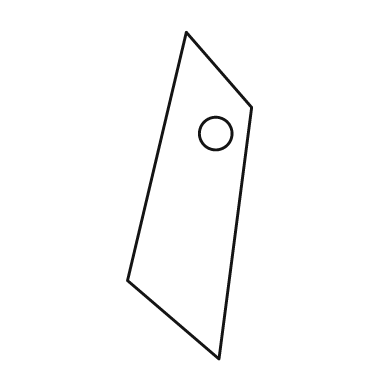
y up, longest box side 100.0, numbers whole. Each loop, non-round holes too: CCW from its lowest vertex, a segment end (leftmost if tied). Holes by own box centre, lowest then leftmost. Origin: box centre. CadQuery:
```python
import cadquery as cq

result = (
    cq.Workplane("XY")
    .moveTo(9.0, -50.0)
    .lineTo(19.0, 27.0)
    .lineTo(-1.0, 50.0)
    .lineTo(-19.0, -26.0)
    .close()
    .moveTo(8.0, 19.0)
    .circle(5.0)
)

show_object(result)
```